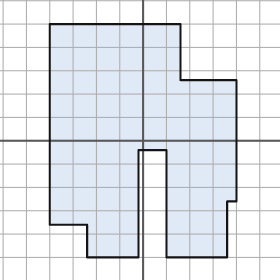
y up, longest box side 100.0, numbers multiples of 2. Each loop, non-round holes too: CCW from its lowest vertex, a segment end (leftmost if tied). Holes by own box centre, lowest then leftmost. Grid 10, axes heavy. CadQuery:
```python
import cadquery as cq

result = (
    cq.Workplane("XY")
    .moveTo(-24.0, -50.0)
    .lineTo(-2.0, -50.0)
    .lineTo(-2.0, -4.0)
    .lineTo(10.0, -4.0)
    .lineTo(10.0, -50.0)
    .lineTo(36.0, -50.0)
    .lineTo(36.0, -26.0)
    .lineTo(40.0, -26.0)
    .lineTo(40.0, 26.0)
    .lineTo(16.0, 26.0)
    .lineTo(16.0, 50.0)
    .lineTo(-40.0, 50.0)
    .lineTo(-40.0, -36.0)
    .lineTo(-24.0, -36.0)
    .close()
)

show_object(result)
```